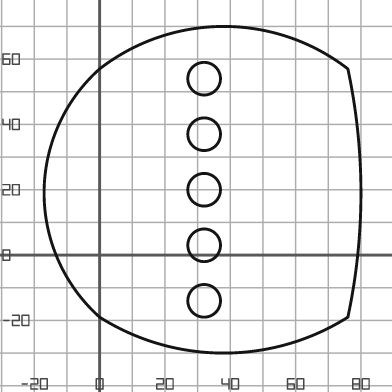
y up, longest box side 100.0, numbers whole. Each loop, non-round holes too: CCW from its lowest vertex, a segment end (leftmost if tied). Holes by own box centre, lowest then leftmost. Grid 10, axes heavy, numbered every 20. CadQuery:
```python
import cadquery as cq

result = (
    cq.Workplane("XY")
    .moveTo(0.0, -19.0)
    .threePointArc((38.0, -30.0), (76.0, -19.0))
    .threePointArc((80.0, 19.0), (76.0, 57.0))
    .threePointArc((38.0, 70.0), (0.0, 57.0))
    .threePointArc((-17.0, 19.0), (0.0, -19.0))
    .close()
    .moveTo(32.0, -14.0)
    .circle(5.0)
    .moveTo(32.0, 3.0)
    .circle(5.0)
    .moveTo(32.0, 20.0)
    .circle(5.0)
    .moveTo(32.0, 37.0)
    .circle(5.0)
    .moveTo(32.0, 54.0)
    .circle(5.0)
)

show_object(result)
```